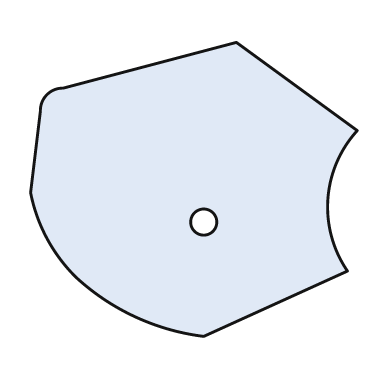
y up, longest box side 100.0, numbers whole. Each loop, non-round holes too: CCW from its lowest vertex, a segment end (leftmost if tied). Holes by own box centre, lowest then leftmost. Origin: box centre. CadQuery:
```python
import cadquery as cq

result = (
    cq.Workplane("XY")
    .moveTo(3.0, -45.0)
    .lineTo(47.0, -25.0)
    .threePointArc((41.0, -3.0), (50.0, 18.0))
    .lineTo(13.0, 45.0)
    .lineTo(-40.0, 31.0)
    .threePointArc((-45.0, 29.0), (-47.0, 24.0))
    .lineTo(-50.0, -1.0)
    .threePointArc((-45.0, -15.0), (-36.0, -27.0))
    .threePointArc((-18.0, -39.0), (3.0, -45.0))
    .close()
    .moveTo(3.0, -10.0)
    .circle(4.0)
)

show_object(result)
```